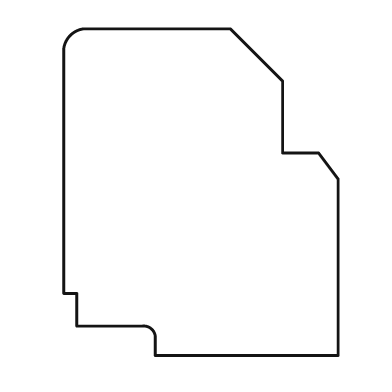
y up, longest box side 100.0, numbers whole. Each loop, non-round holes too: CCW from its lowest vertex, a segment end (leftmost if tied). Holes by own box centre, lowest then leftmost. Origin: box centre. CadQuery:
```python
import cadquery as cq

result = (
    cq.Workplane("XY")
    .moveTo(-14.0, -50.0)
    .lineTo(42.0, -50.0)
    .lineTo(42.0, 4.0)
    .lineTo(36.0, 12.0)
    .lineTo(25.0, 12.0)
    .lineTo(25.0, 34.0)
    .lineTo(9.0, 50.0)
    .lineTo(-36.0, 50.0)
    .threePointArc((-40.0, 48.0), (-42.0, 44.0))
    .lineTo(-42.0, -31.0)
    .lineTo(-38.0, -31.0)
    .lineTo(-38.0, -41.0)
    .lineTo(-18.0, -41.0)
    .threePointArc((-15.0, -42.0), (-14.0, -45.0))
    .close()
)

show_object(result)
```